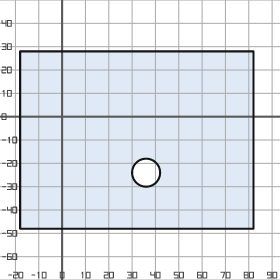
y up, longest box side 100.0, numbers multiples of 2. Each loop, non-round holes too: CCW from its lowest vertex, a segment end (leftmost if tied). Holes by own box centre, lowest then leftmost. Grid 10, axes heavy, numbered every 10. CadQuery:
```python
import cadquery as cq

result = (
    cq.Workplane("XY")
    .moveTo(-18.0, -48.0)
    .lineTo(82.0, -48.0)
    .lineTo(82.0, 28.0)
    .lineTo(-18.0, 28.0)
    .close()
    .moveTo(36.0, -24.0)
    .circle(6.0)
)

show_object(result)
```